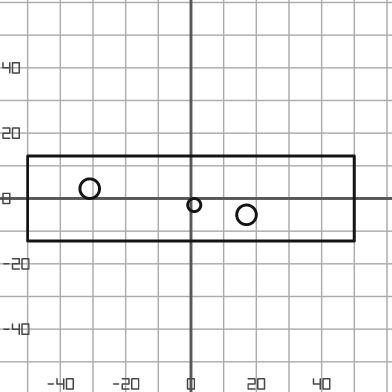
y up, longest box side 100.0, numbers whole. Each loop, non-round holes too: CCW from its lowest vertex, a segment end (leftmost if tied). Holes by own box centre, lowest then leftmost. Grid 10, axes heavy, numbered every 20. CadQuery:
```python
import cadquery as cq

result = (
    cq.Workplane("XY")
    .moveTo(-50.0, -13.0)
    .lineTo(50.0, -13.0)
    .lineTo(50.0, 13.0)
    .lineTo(-50.0, 13.0)
    .close()
    .moveTo(17.0, -5.0)
    .circle(3.0)
    .moveTo(1.0, -2.0)
    .circle(2.0)
    .moveTo(-31.0, 3.0)
    .circle(3.0)
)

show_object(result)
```